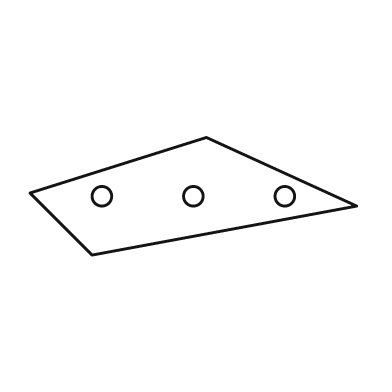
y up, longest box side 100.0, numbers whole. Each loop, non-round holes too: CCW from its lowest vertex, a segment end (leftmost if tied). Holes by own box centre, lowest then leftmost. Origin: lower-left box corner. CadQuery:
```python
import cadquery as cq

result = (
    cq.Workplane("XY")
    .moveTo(19.0, 0.0)
    .lineTo(100.0, 15.0)
    .lineTo(54.0, 36.0)
    .lineTo(0.0, 19.0)
    .close()
    .moveTo(22.0, 18.0)
    .circle(3.0)
    .moveTo(50.0, 18.0)
    .circle(3.0)
    .moveTo(78.0, 18.0)
    .circle(3.0)
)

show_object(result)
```